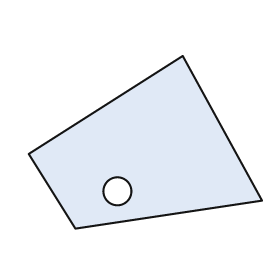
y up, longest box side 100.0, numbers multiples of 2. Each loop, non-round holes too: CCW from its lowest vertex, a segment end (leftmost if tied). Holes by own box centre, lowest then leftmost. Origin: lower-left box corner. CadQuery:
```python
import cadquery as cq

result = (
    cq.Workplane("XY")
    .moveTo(20.0, 0.0)
    .lineTo(100.0, 12.0)
    .lineTo(66.0, 74.0)
    .lineTo(0.0, 32.0)
    .close()
    .moveTo(38.0, 16.0)
    .circle(6.0)
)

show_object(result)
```